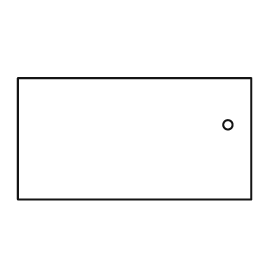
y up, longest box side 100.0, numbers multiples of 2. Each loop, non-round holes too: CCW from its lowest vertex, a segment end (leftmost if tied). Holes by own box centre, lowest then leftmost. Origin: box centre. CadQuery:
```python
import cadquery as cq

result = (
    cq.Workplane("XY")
    .moveTo(-50.0, -26.0)
    .lineTo(50.0, -26.0)
    .lineTo(50.0, 26.0)
    .lineTo(-50.0, 26.0)
    .close()
    .moveTo(40.0, 6.0)
    .circle(2.0)
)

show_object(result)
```